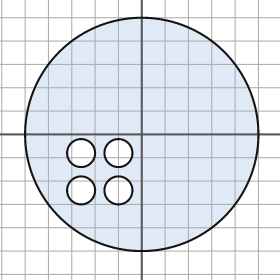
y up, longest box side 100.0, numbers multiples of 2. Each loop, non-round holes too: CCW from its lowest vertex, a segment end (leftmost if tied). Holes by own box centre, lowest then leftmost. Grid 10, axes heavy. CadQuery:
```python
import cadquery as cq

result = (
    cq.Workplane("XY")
    .moveTo(0.0, 0.0)
    .circle(50.0)
    .moveTo(-26.0, -24.0)
    .circle(6.0)
    .moveTo(-10.0, -24.0)
    .circle(6.0)
    .moveTo(-26.0, -8.0)
    .circle(6.0)
    .moveTo(-10.0, -8.0)
    .circle(6.0)
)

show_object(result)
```